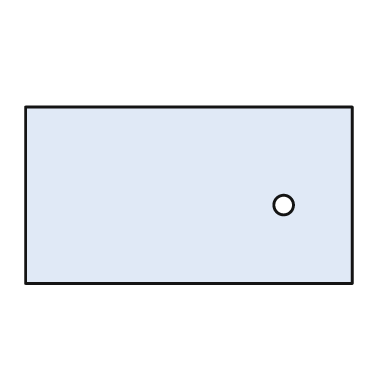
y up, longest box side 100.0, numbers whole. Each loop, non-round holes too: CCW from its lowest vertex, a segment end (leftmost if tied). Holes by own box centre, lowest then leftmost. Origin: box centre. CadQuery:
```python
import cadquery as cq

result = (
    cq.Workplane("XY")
    .moveTo(-50.0, -27.0)
    .lineTo(50.0, -27.0)
    .lineTo(50.0, 27.0)
    .lineTo(-50.0, 27.0)
    .close()
    .moveTo(29.0, -3.0)
    .circle(3.0)
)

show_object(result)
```